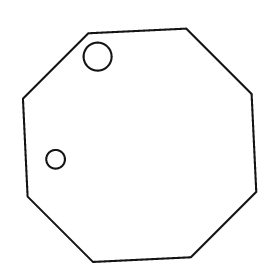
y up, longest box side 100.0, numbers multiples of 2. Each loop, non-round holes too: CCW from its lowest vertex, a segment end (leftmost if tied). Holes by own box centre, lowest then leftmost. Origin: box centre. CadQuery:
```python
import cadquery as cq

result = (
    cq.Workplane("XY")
    .moveTo(-20.0, -50.0)
    .lineTo(22.0, -48.0)
    .lineTo(50.0, -20.0)
    .lineTo(48.0, 22.0)
    .lineTo(20.0, 50.0)
    .lineTo(-22.0, 48.0)
    .lineTo(-50.0, 20.0)
    .lineTo(-48.0, -22.0)
    .close()
    .moveTo(-36.0, -6.0)
    .circle(4.0)
    .moveTo(-18.0, 38.0)
    .circle(6.0)
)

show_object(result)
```